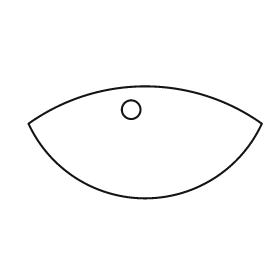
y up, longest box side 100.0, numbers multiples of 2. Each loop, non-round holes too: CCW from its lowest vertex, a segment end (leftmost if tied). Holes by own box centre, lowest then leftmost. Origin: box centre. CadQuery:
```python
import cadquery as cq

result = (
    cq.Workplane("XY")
    .moveTo(-50.0, 8.0)
    .threePointArc((0.0, -24.0), (50.0, 8.0))
    .threePointArc((0.0, 24.0), (-50.0, 8.0))
    .close()
    .moveTo(-6.0, 14.0)
    .circle(4.0)
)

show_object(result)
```